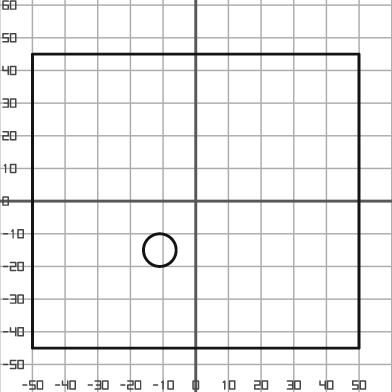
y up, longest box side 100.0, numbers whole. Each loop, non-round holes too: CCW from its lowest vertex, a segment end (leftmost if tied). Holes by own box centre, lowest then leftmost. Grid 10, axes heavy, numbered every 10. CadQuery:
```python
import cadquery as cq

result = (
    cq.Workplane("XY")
    .moveTo(-50.0, -45.0)
    .lineTo(50.0, -45.0)
    .lineTo(50.0, 45.0)
    .lineTo(-50.0, 45.0)
    .close()
    .moveTo(-11.0, -15.0)
    .circle(5.0)
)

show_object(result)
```